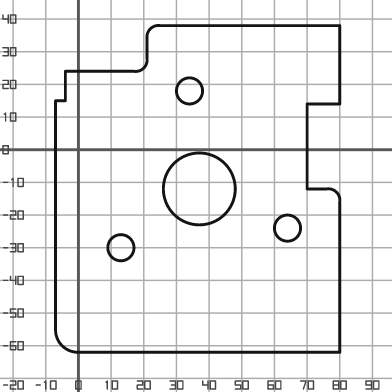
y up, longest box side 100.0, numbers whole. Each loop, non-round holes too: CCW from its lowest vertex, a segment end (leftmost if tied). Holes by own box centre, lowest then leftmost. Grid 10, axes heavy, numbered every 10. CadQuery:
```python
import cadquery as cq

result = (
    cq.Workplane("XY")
    .moveTo(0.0, -62.0)
    .lineTo(80.0, -62.0)
    .lineTo(80.0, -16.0)
    .threePointArc((79.0, -13.0), (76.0, -12.0))
    .lineTo(70.0, -12.0)
    .lineTo(70.0, 14.0)
    .lineTo(80.0, 14.0)
    .lineTo(80.0, 38.0)
    .lineTo(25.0, 38.0)
    .threePointArc((22.0, 37.0), (21.0, 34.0))
    .lineTo(21.0, 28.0)
    .threePointArc((20.0, 25.0), (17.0, 24.0))
    .lineTo(-4.0, 24.0)
    .lineTo(-4.0, 15.0)
    .lineTo(-7.0, 15.0)
    .lineTo(-7.0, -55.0)
    .threePointArc((-5.0, -60.0), (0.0, -62.0))
    .close()
    .moveTo(13.0, -30.0)
    .circle(4.0)
    .moveTo(64.0, -24.0)
    .circle(4.0)
    .moveTo(37.0, -12.0)
    .circle(11.0)
    .moveTo(34.0, 18.0)
    .circle(4.0)
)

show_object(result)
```